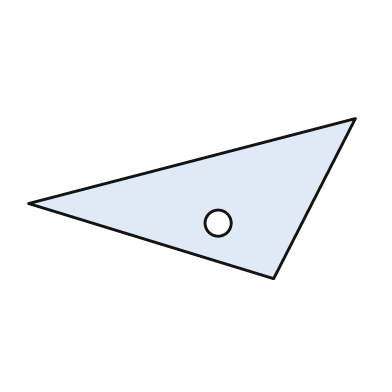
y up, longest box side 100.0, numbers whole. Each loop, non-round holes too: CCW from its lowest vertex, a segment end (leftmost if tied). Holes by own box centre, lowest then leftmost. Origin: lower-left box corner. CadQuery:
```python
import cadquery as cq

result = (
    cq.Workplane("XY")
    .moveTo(75.0, 0.0)
    .lineTo(100.0, 49.0)
    .lineTo(0.0, 23.0)
    .close()
    .moveTo(58.0, 17.0)
    .circle(4.0)
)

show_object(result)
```